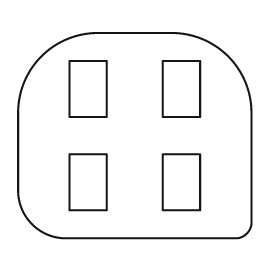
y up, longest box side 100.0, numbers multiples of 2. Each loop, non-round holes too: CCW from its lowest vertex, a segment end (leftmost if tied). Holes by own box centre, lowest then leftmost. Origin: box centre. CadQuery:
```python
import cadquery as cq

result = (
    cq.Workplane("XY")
    .moveTo(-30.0, -44.0)
    .lineTo(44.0, -44.0)
    .threePointArc((48.0, -42.0), (50.0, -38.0))
    .lineTo(50.0, 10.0)
    .threePointArc((40.0, 34.0), (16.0, 44.0))
    .lineTo(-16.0, 44.0)
    .threePointArc((-40.0, 34.0), (-50.0, 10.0))
    .lineTo(-50.0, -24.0)
    .threePointArc((-44.0, -38.0), (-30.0, -44.0))
    .close()
    .moveTo(-28.0, -32.0)
    .lineTo(-12.0, -32.0)
    .lineTo(-12.0, -8.0)
    .lineTo(-28.0, -8.0)
    .close()
    .moveTo(12.0, -32.0)
    .lineTo(28.0, -32.0)
    .lineTo(28.0, -8.0)
    .lineTo(12.0, -8.0)
    .close()
    .moveTo(-28.0, 8.0)
    .lineTo(-12.0, 8.0)
    .lineTo(-12.0, 32.0)
    .lineTo(-28.0, 32.0)
    .close()
    .moveTo(12.0, 8.0)
    .lineTo(28.0, 8.0)
    .lineTo(28.0, 32.0)
    .lineTo(12.0, 32.0)
    .close()
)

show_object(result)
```